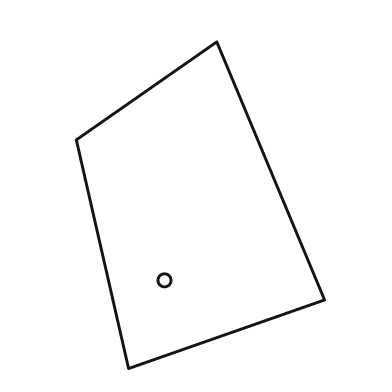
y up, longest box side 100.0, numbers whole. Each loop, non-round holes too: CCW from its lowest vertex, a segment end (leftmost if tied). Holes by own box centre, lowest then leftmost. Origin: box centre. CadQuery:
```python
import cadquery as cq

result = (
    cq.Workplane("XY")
    .moveTo(-22.0, -50.0)
    .lineTo(38.0, -29.0)
    .lineTo(5.0, 50.0)
    .lineTo(-38.0, 20.0)
    .close()
    .moveTo(-11.0, -23.0)
    .circle(2.0)
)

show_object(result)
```